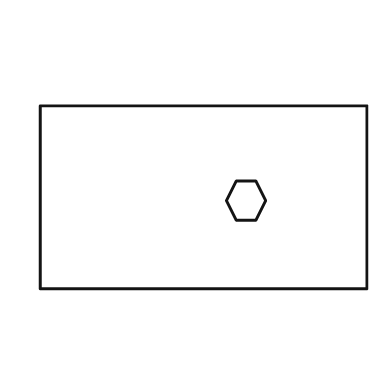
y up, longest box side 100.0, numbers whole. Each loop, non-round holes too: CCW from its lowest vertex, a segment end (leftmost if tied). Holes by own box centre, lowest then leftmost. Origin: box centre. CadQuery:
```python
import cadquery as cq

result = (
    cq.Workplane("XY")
    .moveTo(-50.0, -28.0)
    .lineTo(50.0, -28.0)
    .lineTo(50.0, 28.0)
    .lineTo(-50.0, 28.0)
    .close()
    .moveTo(10.0, -7.0)
    .lineTo(16.0, -7.0)
    .lineTo(19.0, -1.0)
    .lineTo(16.0, 5.0)
    .lineTo(10.0, 5.0)
    .lineTo(7.0, -1.0)
    .close()
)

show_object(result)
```